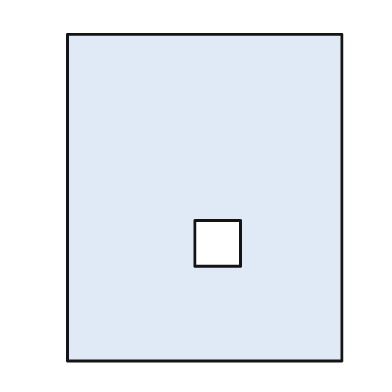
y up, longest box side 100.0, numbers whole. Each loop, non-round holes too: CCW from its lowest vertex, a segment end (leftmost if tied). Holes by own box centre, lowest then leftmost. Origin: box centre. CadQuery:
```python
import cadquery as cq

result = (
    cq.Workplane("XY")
    .moveTo(-42.0, -50.0)
    .lineTo(42.0, -50.0)
    .lineTo(42.0, 50.0)
    .lineTo(-42.0, 50.0)
    .close()
    .moveTo(-3.0, -21.0)
    .lineTo(11.0, -21.0)
    .lineTo(11.0, -7.0)
    .lineTo(-3.0, -7.0)
    .close()
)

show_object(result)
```